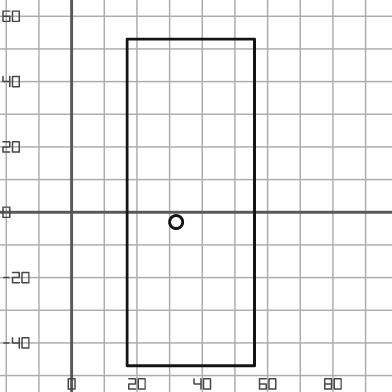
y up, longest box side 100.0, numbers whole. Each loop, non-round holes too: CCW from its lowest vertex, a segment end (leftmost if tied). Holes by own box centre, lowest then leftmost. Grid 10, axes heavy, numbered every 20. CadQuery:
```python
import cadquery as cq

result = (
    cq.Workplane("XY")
    .moveTo(17.0, -47.0)
    .lineTo(56.0, -47.0)
    .lineTo(56.0, 53.0)
    .lineTo(17.0, 53.0)
    .close()
    .moveTo(32.0, -3.0)
    .circle(2.0)
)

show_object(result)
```